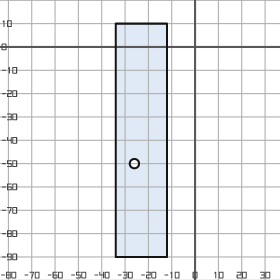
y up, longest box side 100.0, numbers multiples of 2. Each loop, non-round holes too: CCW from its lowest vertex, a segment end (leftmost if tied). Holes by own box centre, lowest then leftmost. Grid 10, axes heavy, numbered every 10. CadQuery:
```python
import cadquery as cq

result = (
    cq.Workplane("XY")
    .moveTo(-34.0, -90.0)
    .lineTo(-12.0, -90.0)
    .lineTo(-12.0, 10.0)
    .lineTo(-34.0, 10.0)
    .close()
    .moveTo(-26.0, -50.0)
    .circle(2.0)
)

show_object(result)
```